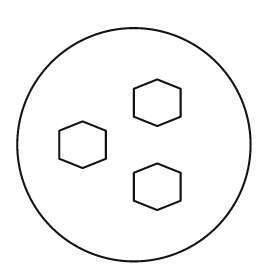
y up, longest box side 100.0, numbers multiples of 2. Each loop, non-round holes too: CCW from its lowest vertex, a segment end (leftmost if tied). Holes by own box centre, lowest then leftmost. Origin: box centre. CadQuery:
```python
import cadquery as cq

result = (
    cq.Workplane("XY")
    .moveTo(0.0, 0.0)
    .circle(50.0)
    .moveTo(10.0, -28.0)
    .lineTo(20.0, -24.0)
    .lineTo(20.0, -12.0)
    .lineTo(10.0, -8.0)
    .lineTo(0.0, -12.0)
    .lineTo(0.0, -24.0)
    .close()
    .moveTo(-22.0, -10.0)
    .lineTo(-12.0, -6.0)
    .lineTo(-12.0, 6.0)
    .lineTo(-22.0, 10.0)
    .lineTo(-32.0, 6.0)
    .lineTo(-32.0, -6.0)
    .close()
    .moveTo(10.0, 8.0)
    .lineTo(20.0, 12.0)
    .lineTo(20.0, 24.0)
    .lineTo(10.0, 28.0)
    .lineTo(0.0, 24.0)
    .lineTo(0.0, 12.0)
    .close()
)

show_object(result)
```